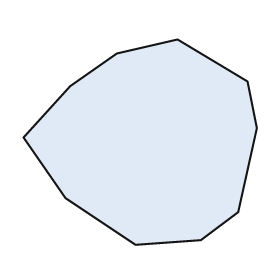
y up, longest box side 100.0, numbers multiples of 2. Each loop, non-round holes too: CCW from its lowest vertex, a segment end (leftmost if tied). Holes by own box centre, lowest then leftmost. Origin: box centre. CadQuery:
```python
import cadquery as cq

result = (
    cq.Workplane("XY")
    .moveTo(-2.0, -44.0)
    .lineTo(26.0, -42.0)
    .lineTo(42.0, -30.0)
    .lineTo(50.0, 6.0)
    .lineTo(46.0, 26.0)
    .lineTo(16.0, 44.0)
    .lineTo(-10.0, 38.0)
    .lineTo(-30.0, 24.0)
    .lineTo(-50.0, 2.0)
    .lineTo(-32.0, -24.0)
    .close()
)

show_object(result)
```